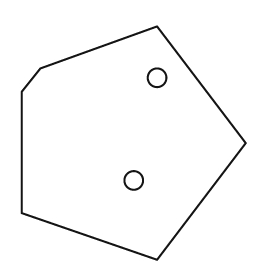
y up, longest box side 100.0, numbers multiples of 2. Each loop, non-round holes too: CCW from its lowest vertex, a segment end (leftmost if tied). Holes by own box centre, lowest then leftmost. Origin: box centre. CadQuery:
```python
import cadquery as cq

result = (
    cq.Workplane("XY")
    .moveTo(10.0, -50.0)
    .lineTo(48.0, 0.0)
    .lineTo(10.0, 50.0)
    .lineTo(-40.0, 32.0)
    .lineTo(-48.0, 22.0)
    .lineTo(-48.0, -30.0)
    .close()
    .moveTo(0.0, -16.0)
    .circle(4.0)
    .moveTo(10.0, 28.0)
    .circle(4.0)
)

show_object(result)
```